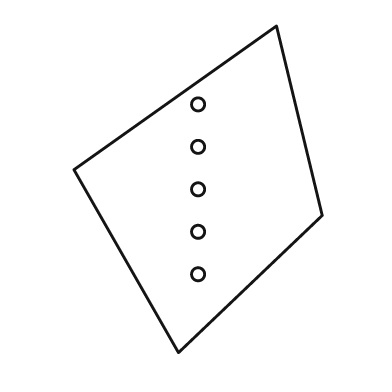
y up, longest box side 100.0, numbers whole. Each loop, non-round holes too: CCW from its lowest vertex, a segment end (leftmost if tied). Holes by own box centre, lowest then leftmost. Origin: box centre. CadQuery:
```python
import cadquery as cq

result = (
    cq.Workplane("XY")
    .moveTo(-6.0, -50.0)
    .lineTo(38.0, -8.0)
    .lineTo(24.0, 50.0)
    .lineTo(-38.0, 6.0)
    .close()
    .moveTo(0.0, -26.0)
    .circle(2.0)
    .moveTo(0.0, -13.0)
    .circle(2.0)
    .moveTo(0.0, 0.0)
    .circle(2.0)
    .moveTo(0.0, 13.0)
    .circle(2.0)
    .moveTo(0.0, 26.0)
    .circle(2.0)
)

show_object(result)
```